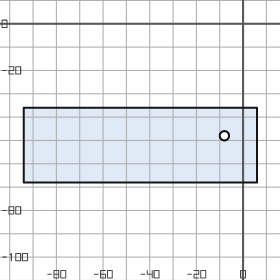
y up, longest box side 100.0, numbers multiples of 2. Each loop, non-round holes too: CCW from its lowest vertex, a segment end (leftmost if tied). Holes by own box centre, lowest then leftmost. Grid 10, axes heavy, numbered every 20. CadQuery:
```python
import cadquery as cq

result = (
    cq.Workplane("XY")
    .moveTo(-94.0, -68.0)
    .lineTo(6.0, -68.0)
    .lineTo(6.0, -36.0)
    .lineTo(-94.0, -36.0)
    .close()
    .moveTo(-8.0, -48.0)
    .circle(2.0)
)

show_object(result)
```